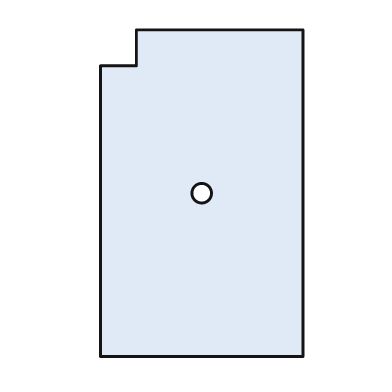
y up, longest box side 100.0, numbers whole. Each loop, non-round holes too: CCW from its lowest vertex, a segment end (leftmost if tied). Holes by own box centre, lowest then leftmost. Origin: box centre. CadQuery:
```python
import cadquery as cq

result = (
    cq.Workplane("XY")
    .moveTo(-31.0, -50.0)
    .lineTo(31.0, -50.0)
    .lineTo(31.0, 50.0)
    .lineTo(-20.0, 50.0)
    .lineTo(-20.0, 39.0)
    .lineTo(-31.0, 39.0)
    .close()
    .moveTo(0.0, 0.0)
    .circle(3.0)
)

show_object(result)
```